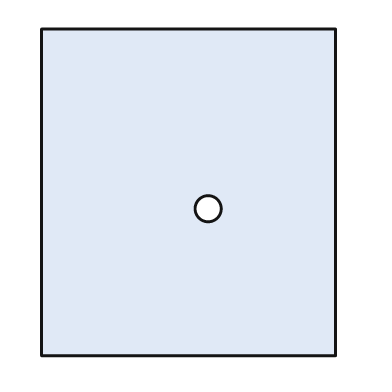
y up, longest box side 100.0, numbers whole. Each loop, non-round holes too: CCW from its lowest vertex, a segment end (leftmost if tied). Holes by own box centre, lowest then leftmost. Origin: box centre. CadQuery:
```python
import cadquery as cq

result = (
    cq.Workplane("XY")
    .moveTo(-45.0, -50.0)
    .lineTo(45.0, -50.0)
    .lineTo(45.0, 50.0)
    .lineTo(-45.0, 50.0)
    .close()
    .moveTo(6.0, -5.0)
    .circle(4.0)
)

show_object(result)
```